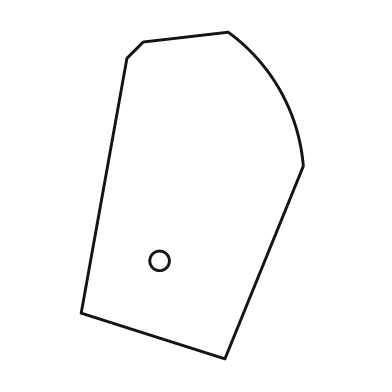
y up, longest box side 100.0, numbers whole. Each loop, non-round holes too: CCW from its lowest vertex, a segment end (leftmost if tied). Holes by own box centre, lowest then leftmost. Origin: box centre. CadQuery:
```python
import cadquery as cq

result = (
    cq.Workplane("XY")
    .moveTo(10.0, -50.0)
    .lineTo(34.0, 9.0)
    .threePointArc((27.0, 32.0), (11.0, 50.0))
    .lineTo(-15.0, 47.0)
    .lineTo(-20.0, 42.0)
    .lineTo(-34.0, -36.0)
    .close()
    .moveTo(-10.0, -20.0)
    .circle(3.0)
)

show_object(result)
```